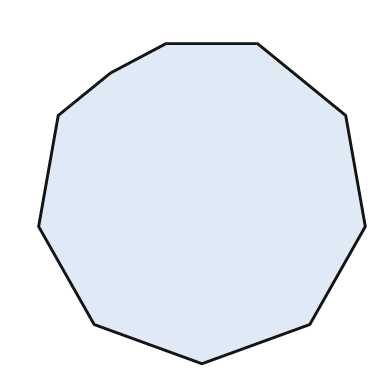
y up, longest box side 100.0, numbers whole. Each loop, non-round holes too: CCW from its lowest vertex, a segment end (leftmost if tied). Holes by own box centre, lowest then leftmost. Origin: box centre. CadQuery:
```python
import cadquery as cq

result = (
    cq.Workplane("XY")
    .moveTo(0.0, -49.0)
    .lineTo(33.0, -37.0)
    .lineTo(50.0, -7.0)
    .lineTo(44.0, 27.0)
    .lineTo(17.0, 49.0)
    .lineTo(-11.0, 49.0)
    .lineTo(-28.0, 40.0)
    .lineTo(-44.0, 27.0)
    .lineTo(-50.0, -7.0)
    .lineTo(-33.0, -37.0)
    .close()
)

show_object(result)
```